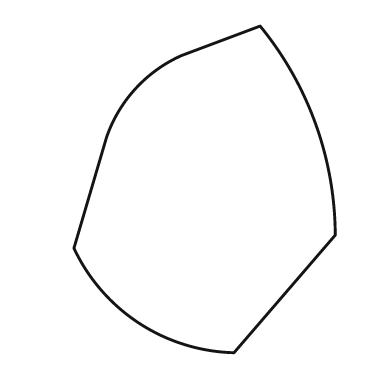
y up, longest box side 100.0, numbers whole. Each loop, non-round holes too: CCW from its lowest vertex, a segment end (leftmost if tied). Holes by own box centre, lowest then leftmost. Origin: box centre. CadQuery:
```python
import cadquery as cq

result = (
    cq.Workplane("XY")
    .moveTo(9.0, -50.0)
    .lineTo(40.0, -14.0)
    .threePointArc((34.0, 20.0), (17.0, 50.0))
    .lineTo(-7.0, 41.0)
    .threePointArc((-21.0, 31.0), (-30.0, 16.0))
    .lineTo(-40.0, -18.0)
    .threePointArc((-20.0, -41.0), (9.0, -50.0))
    .close()
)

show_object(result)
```